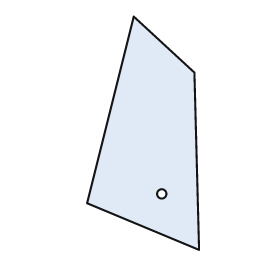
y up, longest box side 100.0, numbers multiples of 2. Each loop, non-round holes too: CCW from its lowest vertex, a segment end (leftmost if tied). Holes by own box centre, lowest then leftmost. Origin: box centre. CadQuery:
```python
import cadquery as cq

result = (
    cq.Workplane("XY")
    .moveTo(24.0, -50.0)
    .lineTo(22.0, 26.0)
    .lineTo(-4.0, 50.0)
    .lineTo(-24.0, -30.0)
    .close()
    .moveTo(8.0, -26.0)
    .circle(2.0)
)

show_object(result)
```